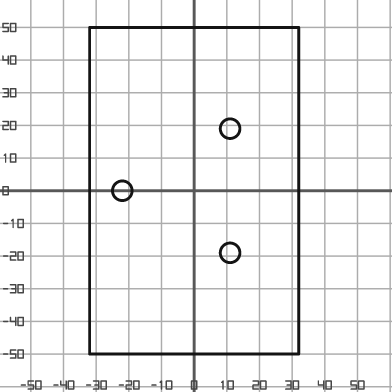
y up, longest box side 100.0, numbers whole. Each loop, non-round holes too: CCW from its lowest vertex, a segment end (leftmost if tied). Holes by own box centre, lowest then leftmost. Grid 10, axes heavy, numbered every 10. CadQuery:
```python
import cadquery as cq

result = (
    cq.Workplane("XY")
    .moveTo(-32.0, -50.0)
    .lineTo(32.0, -50.0)
    .lineTo(32.0, 50.0)
    .lineTo(-32.0, 50.0)
    .close()
    .moveTo(11.0, -19.0)
    .circle(3.0)
    .moveTo(-22.0, 0.0)
    .circle(3.0)
    .moveTo(11.0, 19.0)
    .circle(3.0)
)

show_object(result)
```